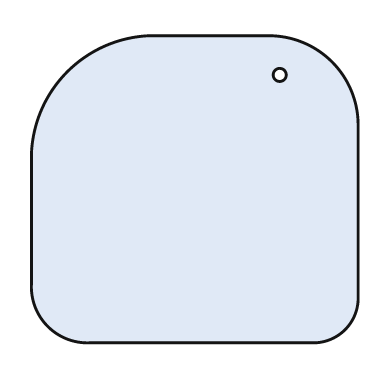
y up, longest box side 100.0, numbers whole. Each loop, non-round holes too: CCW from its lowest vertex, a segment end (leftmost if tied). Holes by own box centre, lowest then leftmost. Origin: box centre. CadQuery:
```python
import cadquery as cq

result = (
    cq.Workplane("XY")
    .moveTo(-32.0, -47.0)
    .lineTo(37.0, -47.0)
    .threePointArc((46.0, -43.0), (50.0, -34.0))
    .lineTo(50.0, 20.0)
    .threePointArc((42.0, 39.0), (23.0, 47.0))
    .lineTo(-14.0, 47.0)
    .threePointArc((-39.0, 36.0), (-50.0, 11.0))
    .lineTo(-50.0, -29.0)
    .threePointArc((-45.0, -42.0), (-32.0, -47.0))
    .close()
    .moveTo(26.0, 35.0)
    .circle(2.0)
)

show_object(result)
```